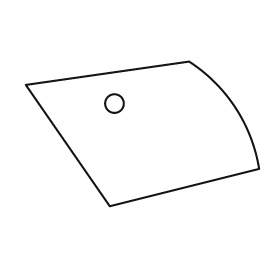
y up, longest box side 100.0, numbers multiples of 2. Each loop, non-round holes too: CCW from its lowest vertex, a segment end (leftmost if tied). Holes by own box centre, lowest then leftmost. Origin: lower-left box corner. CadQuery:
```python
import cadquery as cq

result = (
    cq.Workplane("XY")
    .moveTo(36.0, 0.0)
    .lineTo(100.0, 16.0)
    .threePointArc((90.0, 42.0), (70.0, 62.0))
    .lineTo(0.0, 52.0)
    .close()
    .moveTo(38.0, 44.0)
    .circle(4.0)
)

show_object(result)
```